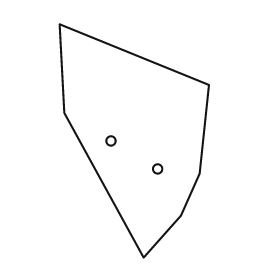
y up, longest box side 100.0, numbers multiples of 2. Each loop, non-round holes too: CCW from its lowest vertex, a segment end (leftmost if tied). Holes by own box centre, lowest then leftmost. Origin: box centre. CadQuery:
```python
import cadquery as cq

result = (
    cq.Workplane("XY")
    .moveTo(4.0, -50.0)
    .lineTo(20.0, -32.0)
    .lineTo(28.0, -14.0)
    .lineTo(32.0, 24.0)
    .lineTo(-32.0, 50.0)
    .lineTo(-30.0, 12.0)
    .close()
    .moveTo(10.0, -12.0)
    .circle(2.0)
    .moveTo(-10.0, 0.0)
    .circle(2.0)
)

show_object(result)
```